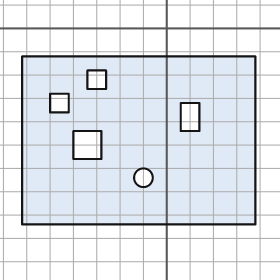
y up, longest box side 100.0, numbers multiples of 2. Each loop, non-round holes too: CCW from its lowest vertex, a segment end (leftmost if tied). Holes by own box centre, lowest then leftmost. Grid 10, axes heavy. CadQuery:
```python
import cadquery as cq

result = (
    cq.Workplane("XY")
    .moveTo(-62.0, -84.0)
    .lineTo(38.0, -84.0)
    .lineTo(38.0, -12.0)
    .lineTo(-62.0, -12.0)
    .close()
    .moveTo(-10.0, -64.0)
    .circle(4.0)
    .moveTo(-40.0, -56.0)
    .lineTo(-28.0, -56.0)
    .lineTo(-28.0, -44.0)
    .lineTo(-40.0, -44.0)
    .close()
    .moveTo(6.0, -44.0)
    .lineTo(14.0, -44.0)
    .lineTo(14.0, -32.0)
    .lineTo(6.0, -32.0)
    .close()
    .moveTo(-50.0, -36.0)
    .lineTo(-42.0, -36.0)
    .lineTo(-42.0, -28.0)
    .lineTo(-50.0, -28.0)
    .close()
    .moveTo(-34.0, -26.0)
    .lineTo(-26.0, -26.0)
    .lineTo(-26.0, -18.0)
    .lineTo(-34.0, -18.0)
    .close()
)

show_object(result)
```